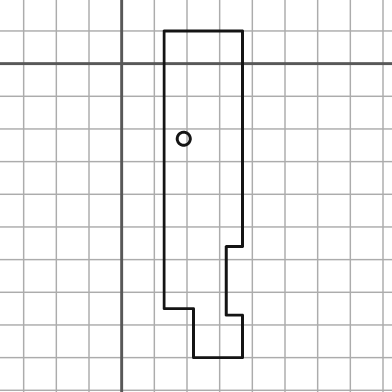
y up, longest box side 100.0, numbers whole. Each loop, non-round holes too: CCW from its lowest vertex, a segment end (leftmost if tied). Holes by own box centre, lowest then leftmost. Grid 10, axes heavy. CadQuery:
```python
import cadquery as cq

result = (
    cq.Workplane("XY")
    .moveTo(22.0, -90.0)
    .lineTo(37.0, -90.0)
    .lineTo(37.0, -77.0)
    .lineTo(32.0, -77.0)
    .lineTo(32.0, -56.0)
    .lineTo(37.0, -56.0)
    .lineTo(37.0, 10.0)
    .lineTo(13.0, 10.0)
    .lineTo(13.0, -75.0)
    .lineTo(22.0, -75.0)
    .close()
    .moveTo(19.0, -23.0)
    .circle(2.0)
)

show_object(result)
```